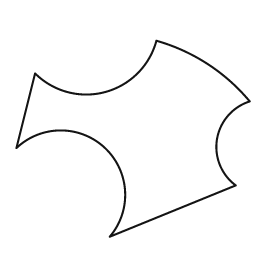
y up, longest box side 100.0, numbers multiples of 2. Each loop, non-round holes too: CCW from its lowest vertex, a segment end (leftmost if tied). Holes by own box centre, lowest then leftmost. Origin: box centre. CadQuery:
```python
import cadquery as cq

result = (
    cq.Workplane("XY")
    .moveTo(-10.0, -42.0)
    .lineTo(44.0, -20.0)
    .threePointArc((36.0, 0.0), (50.0, 16.0))
    .threePointArc((32.0, 32.0), (10.0, 42.0))
    .threePointArc((-12.0, 20.0), (-42.0, 28.0))
    .lineTo(-50.0, -4.0)
    .threePointArc((-12.0, -4.0), (-10.0, -42.0))
    .close()
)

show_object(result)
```